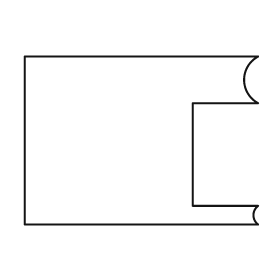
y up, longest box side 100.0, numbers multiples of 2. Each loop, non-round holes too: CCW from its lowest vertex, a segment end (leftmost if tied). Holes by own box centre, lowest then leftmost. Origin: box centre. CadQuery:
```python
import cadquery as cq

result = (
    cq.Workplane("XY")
    .moveTo(-50.0, -36.0)
    .lineTo(50.0, -36.0)
    .threePointArc((48.0, -32.0), (50.0, -28.0))
    .lineTo(22.0, -28.0)
    .lineTo(22.0, 16.0)
    .lineTo(50.0, 16.0)
    .threePointArc((44.0, 26.0), (50.0, 36.0))
    .lineTo(-50.0, 36.0)
    .close()
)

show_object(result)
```